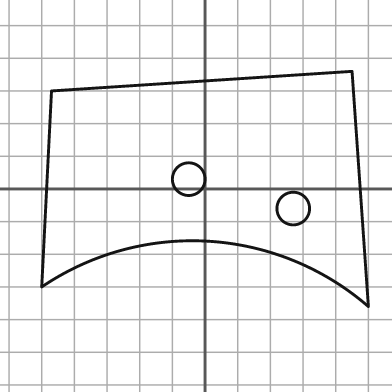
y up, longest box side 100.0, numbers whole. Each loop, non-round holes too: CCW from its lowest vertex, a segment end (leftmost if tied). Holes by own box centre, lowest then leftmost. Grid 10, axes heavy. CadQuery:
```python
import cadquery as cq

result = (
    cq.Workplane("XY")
    .moveTo(50.0, -36.0)
    .lineTo(45.0, 36.0)
    .lineTo(-47.0, 30.0)
    .lineTo(-50.0, -30.0)
    .threePointArc((1.0, -16.0), (50.0, -36.0))
    .close()
    .moveTo(27.0, -6.0)
    .circle(5.0)
    .moveTo(-5.0, 3.0)
    .circle(5.0)
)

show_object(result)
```